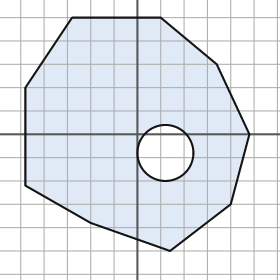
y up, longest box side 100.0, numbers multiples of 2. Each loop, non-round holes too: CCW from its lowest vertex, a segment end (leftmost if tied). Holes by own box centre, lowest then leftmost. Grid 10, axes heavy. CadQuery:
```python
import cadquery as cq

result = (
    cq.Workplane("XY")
    .moveTo(14.0, -50.0)
    .lineTo(40.0, -30.0)
    .lineTo(48.0, 0.0)
    .lineTo(34.0, 30.0)
    .lineTo(10.0, 50.0)
    .lineTo(-28.0, 50.0)
    .lineTo(-48.0, 20.0)
    .lineTo(-48.0, -22.0)
    .lineTo(-20.0, -38.0)
    .close()
    .moveTo(12.0, -8.0)
    .circle(12.0)
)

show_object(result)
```